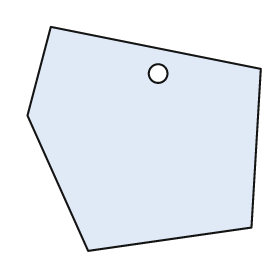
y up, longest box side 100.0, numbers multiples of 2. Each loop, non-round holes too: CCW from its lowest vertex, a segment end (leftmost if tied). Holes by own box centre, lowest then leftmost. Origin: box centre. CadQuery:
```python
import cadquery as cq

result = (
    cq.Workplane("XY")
    .moveTo(-24.0, -48.0)
    .lineTo(46.0, -38.0)
    .lineTo(50.0, 30.0)
    .lineTo(-40.0, 48.0)
    .lineTo(-50.0, 10.0)
    .close()
    .moveTo(6.0, 28.0)
    .circle(4.0)
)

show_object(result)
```